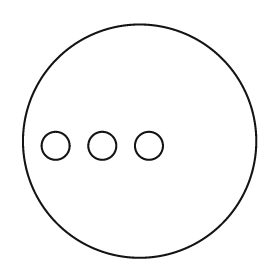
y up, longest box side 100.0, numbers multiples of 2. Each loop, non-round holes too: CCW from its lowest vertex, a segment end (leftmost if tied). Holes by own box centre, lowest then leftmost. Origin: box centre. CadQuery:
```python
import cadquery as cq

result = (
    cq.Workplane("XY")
    .moveTo(0.0, 0.0)
    .circle(50.0)
    .moveTo(-36.0, -2.0)
    .circle(6.0)
    .moveTo(-16.0, -2.0)
    .circle(6.0)
    .moveTo(4.0, -2.0)
    .circle(6.0)
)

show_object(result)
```